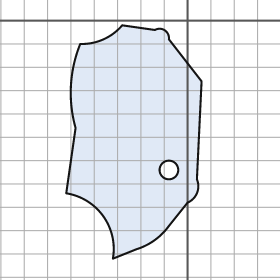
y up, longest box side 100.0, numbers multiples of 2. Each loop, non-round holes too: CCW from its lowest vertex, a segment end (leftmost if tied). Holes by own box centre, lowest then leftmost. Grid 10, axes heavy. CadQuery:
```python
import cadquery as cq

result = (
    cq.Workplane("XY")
    .moveTo(-32.0, -102.0)
    .lineTo(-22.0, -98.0)
    .threePointArc((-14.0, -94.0), (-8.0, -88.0))
    .lineTo(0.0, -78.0)
    .threePointArc((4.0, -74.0), (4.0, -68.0))
    .lineTo(6.0, -26.0)
    .lineTo(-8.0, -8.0)
    .threePointArc((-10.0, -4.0), (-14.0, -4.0))
    .lineTo(-28.0, -2.0)
    .threePointArc((-36.0, -8.0), (-46.0, -10.0))
    .threePointArc((-50.0, -28.0), (-48.0, -46.0))
    .lineTo(-52.0, -74.0)
    .threePointArc((-36.0, -84.0), (-32.0, -102.0))
    .close()
    .moveTo(-8.0, -64.0)
    .circle(4.0)
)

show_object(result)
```